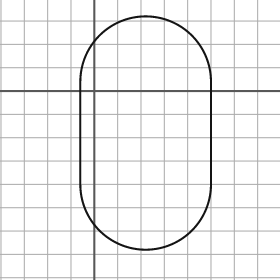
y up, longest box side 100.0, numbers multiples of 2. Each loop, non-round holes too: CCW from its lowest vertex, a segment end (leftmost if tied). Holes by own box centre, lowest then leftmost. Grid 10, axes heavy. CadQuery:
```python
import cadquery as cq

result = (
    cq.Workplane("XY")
    .moveTo(-6.0, -40.0)
    .threePointArc((22.0, -68.0), (50.0, -40.0))
    .lineTo(50.0, 4.0)
    .threePointArc((22.0, 32.0), (-6.0, 4.0))
    .close()
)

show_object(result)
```